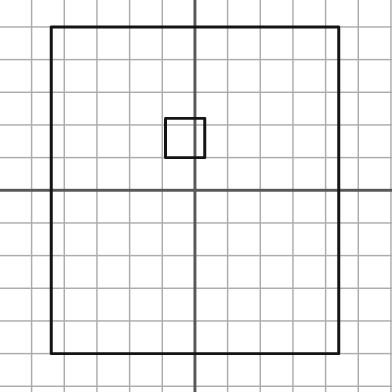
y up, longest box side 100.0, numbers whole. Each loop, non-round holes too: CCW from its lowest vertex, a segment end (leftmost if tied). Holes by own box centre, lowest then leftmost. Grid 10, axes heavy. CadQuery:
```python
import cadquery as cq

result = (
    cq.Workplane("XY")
    .moveTo(-44.0, -50.0)
    .lineTo(44.0, -50.0)
    .lineTo(44.0, 50.0)
    .lineTo(-44.0, 50.0)
    .close()
    .moveTo(-9.0, 10.0)
    .lineTo(3.0, 10.0)
    .lineTo(3.0, 22.0)
    .lineTo(-9.0, 22.0)
    .close()
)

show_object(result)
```